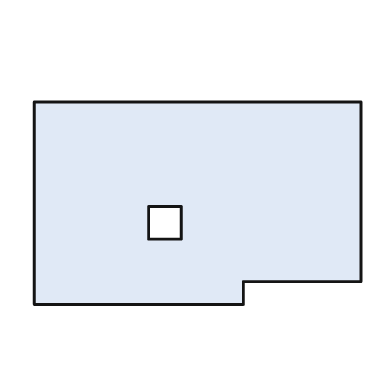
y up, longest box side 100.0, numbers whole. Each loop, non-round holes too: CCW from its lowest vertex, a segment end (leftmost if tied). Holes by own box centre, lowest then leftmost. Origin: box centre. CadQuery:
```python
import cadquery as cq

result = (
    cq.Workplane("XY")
    .moveTo(-50.0, -31.0)
    .lineTo(14.0, -31.0)
    .lineTo(14.0, -24.0)
    .lineTo(50.0, -24.0)
    .lineTo(50.0, 31.0)
    .lineTo(-50.0, 31.0)
    .close()
    .moveTo(-15.0, -11.0)
    .lineTo(-5.0, -11.0)
    .lineTo(-5.0, -1.0)
    .lineTo(-15.0, -1.0)
    .close()
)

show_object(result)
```